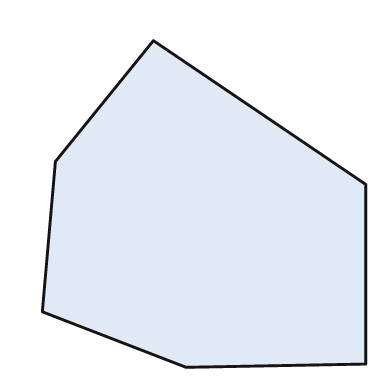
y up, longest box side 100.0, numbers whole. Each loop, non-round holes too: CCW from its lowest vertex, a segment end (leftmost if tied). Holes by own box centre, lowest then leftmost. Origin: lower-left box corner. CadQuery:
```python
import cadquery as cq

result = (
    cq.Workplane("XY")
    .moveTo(44.0, 0.0)
    .lineTo(99.0, 1.0)
    .lineTo(99.0, 56.0)
    .lineTo(34.0, 100.0)
    .lineTo(4.0, 63.0)
    .lineTo(0.0, 17.0)
    .close()
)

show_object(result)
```